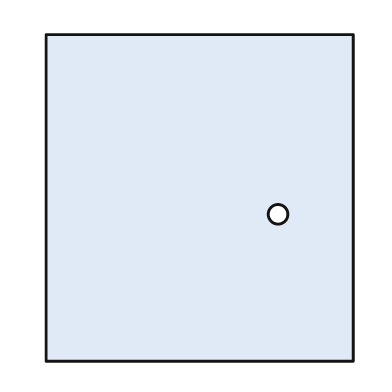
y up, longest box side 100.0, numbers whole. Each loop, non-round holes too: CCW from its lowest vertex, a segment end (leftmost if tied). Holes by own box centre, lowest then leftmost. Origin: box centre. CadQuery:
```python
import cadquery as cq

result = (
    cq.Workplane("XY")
    .moveTo(-47.0, -50.0)
    .lineTo(47.0, -50.0)
    .lineTo(47.0, 50.0)
    .lineTo(-47.0, 50.0)
    .close()
    .moveTo(24.0, -5.0)
    .circle(3.0)
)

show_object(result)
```